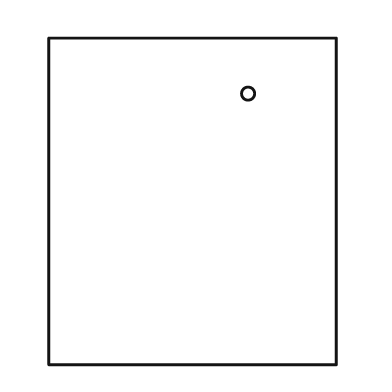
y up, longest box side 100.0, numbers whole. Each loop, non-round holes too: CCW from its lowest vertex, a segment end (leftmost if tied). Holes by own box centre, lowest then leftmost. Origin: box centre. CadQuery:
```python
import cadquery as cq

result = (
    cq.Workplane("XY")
    .moveTo(-44.0, -50.0)
    .lineTo(44.0, -50.0)
    .lineTo(44.0, 50.0)
    .lineTo(-44.0, 50.0)
    .close()
    .moveTo(17.0, 33.0)
    .circle(2.0)
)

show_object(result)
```